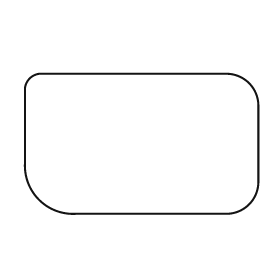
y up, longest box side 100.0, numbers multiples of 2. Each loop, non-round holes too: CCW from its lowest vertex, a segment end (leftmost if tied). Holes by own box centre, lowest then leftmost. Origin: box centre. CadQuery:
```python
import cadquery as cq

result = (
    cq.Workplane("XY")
    .moveTo(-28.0, -30.0)
    .lineTo(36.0, -30.0)
    .threePointArc((46.0, -26.0), (50.0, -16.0))
    .lineTo(50.0, 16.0)
    .threePointArc((46.0, 26.0), (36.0, 30.0))
    .lineTo(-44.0, 30.0)
    .threePointArc((-48.0, 28.0), (-50.0, 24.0))
    .lineTo(-50.0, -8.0)
    .threePointArc((-44.0, -24.0), (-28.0, -30.0))
    .close()
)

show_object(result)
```